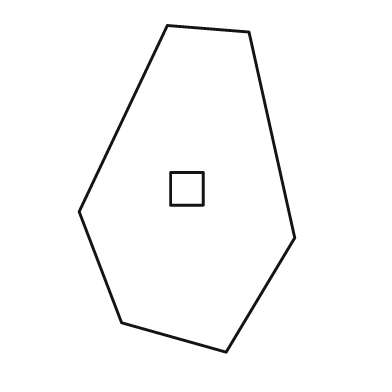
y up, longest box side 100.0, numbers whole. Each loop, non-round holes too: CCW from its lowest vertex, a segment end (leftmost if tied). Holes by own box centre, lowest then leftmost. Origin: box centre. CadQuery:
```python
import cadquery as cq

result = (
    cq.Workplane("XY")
    .moveTo(12.0, -50.0)
    .lineTo(33.0, -15.0)
    .lineTo(19.0, 48.0)
    .lineTo(-6.0, 50.0)
    .lineTo(-33.0, -7.0)
    .lineTo(-20.0, -41.0)
    .close()
    .moveTo(-5.0, -5.0)
    .lineTo(5.0, -5.0)
    .lineTo(5.0, 5.0)
    .lineTo(-5.0, 5.0)
    .close()
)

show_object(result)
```